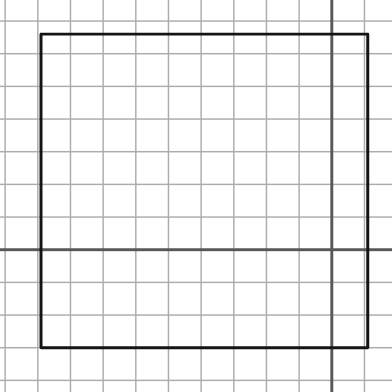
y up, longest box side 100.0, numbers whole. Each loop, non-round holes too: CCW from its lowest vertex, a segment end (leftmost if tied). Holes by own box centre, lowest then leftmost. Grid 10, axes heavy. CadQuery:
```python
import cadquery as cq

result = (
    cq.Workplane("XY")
    .moveTo(-89.0, -30.0)
    .lineTo(11.0, -30.0)
    .lineTo(11.0, 66.0)
    .lineTo(-89.0, 66.0)
    .close()
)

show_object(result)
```